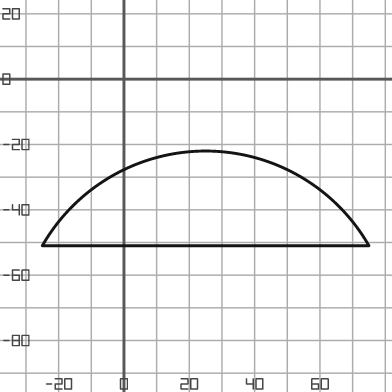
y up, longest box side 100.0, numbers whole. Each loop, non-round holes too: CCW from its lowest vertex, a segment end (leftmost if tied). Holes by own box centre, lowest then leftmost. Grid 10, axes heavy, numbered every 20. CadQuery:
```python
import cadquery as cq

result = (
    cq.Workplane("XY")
    .moveTo(-25.0, -51.0)
    .lineTo(75.0, -51.0)
    .threePointArc((25.0, -22.0), (-25.0, -51.0))
    .close()
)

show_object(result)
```